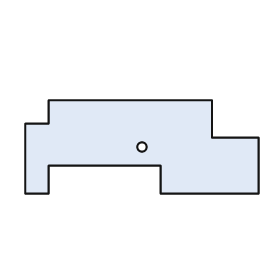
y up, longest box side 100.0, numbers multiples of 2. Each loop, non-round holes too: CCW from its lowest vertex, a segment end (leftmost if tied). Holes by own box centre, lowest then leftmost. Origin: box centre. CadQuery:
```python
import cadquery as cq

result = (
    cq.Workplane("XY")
    .moveTo(-50.0, -20.0)
    .lineTo(-40.0, -20.0)
    .lineTo(-40.0, -8.0)
    .lineTo(8.0, -8.0)
    .lineTo(8.0, -20.0)
    .lineTo(50.0, -20.0)
    .lineTo(50.0, 4.0)
    .lineTo(30.0, 4.0)
    .lineTo(30.0, 20.0)
    .lineTo(-40.0, 20.0)
    .lineTo(-40.0, 10.0)
    .lineTo(-50.0, 10.0)
    .close()
    .moveTo(0.0, 0.0)
    .circle(2.0)
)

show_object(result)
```